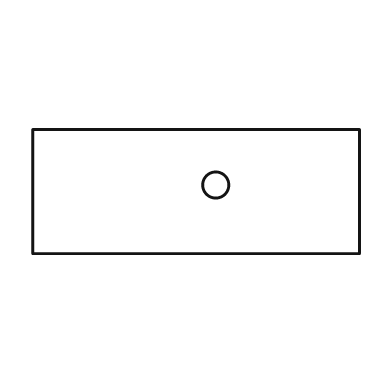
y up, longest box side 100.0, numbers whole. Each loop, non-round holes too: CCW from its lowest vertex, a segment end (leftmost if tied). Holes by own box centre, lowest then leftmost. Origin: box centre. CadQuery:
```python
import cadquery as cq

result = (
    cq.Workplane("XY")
    .moveTo(-50.0, -19.0)
    .lineTo(50.0, -19.0)
    .lineTo(50.0, 19.0)
    .lineTo(-50.0, 19.0)
    .close()
    .moveTo(6.0, 2.0)
    .circle(4.0)
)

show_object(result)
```